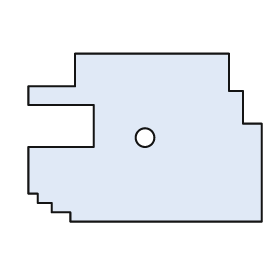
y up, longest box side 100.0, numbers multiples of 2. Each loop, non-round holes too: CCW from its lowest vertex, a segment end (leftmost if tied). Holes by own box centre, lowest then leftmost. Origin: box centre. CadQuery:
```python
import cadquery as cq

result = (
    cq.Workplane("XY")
    .moveTo(-32.0, -36.0)
    .lineTo(50.0, -36.0)
    .lineTo(50.0, 6.0)
    .lineTo(42.0, 6.0)
    .lineTo(42.0, 20.0)
    .lineTo(36.0, 20.0)
    .lineTo(36.0, 36.0)
    .lineTo(-30.0, 36.0)
    .lineTo(-30.0, 22.0)
    .lineTo(-50.0, 22.0)
    .lineTo(-50.0, 14.0)
    .lineTo(-22.0, 14.0)
    .lineTo(-22.0, -4.0)
    .lineTo(-50.0, -4.0)
    .lineTo(-50.0, -24.0)
    .lineTo(-46.0, -24.0)
    .lineTo(-46.0, -28.0)
    .lineTo(-40.0, -28.0)
    .lineTo(-40.0, -32.0)
    .lineTo(-32.0, -32.0)
    .close()
    .moveTo(0.0, 0.0)
    .circle(4.0)
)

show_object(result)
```